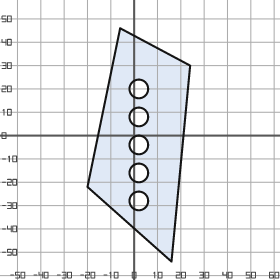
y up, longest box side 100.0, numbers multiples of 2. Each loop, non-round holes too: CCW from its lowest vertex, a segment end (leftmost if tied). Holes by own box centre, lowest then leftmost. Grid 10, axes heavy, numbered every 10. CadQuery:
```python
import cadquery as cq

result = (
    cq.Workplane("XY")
    .moveTo(16.0, -54.0)
    .lineTo(24.0, 30.0)
    .lineTo(-6.0, 46.0)
    .lineTo(-20.0, -22.0)
    .close()
    .moveTo(2.0, -28.0)
    .circle(4.0)
    .moveTo(2.0, -16.0)
    .circle(4.0)
    .moveTo(2.0, -4.0)
    .circle(4.0)
    .moveTo(2.0, 8.0)
    .circle(4.0)
    .moveTo(2.0, 20.0)
    .circle(4.0)
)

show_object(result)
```